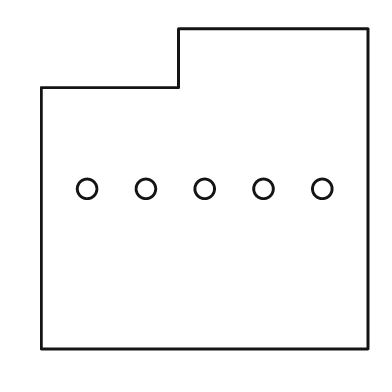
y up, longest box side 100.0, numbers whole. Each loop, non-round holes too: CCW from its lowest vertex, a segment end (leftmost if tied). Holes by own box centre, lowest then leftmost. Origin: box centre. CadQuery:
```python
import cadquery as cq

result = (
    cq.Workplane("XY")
    .moveTo(-50.0, -49.0)
    .lineTo(50.0, -49.0)
    .lineTo(50.0, 49.0)
    .lineTo(-8.0, 49.0)
    .lineTo(-8.0, 31.0)
    .lineTo(-50.0, 31.0)
    .close()
    .moveTo(-36.0, 0.0)
    .circle(3.0)
    .moveTo(-18.0, 0.0)
    .circle(3.0)
    .moveTo(0.0, 0.0)
    .circle(3.0)
    .moveTo(18.0, 0.0)
    .circle(3.0)
    .moveTo(36.0, 0.0)
    .circle(3.0)
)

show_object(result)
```